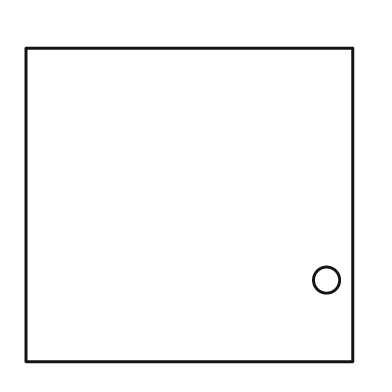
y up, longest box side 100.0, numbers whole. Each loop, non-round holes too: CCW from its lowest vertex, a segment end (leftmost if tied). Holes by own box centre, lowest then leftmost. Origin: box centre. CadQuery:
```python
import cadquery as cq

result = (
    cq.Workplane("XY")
    .moveTo(-50.0, -48.0)
    .lineTo(50.0, -48.0)
    .lineTo(50.0, 48.0)
    .lineTo(-50.0, 48.0)
    .close()
    .moveTo(42.0, -23.0)
    .circle(4.0)
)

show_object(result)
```